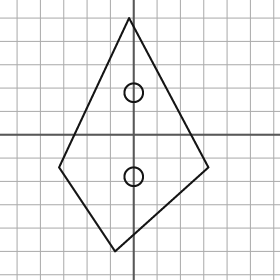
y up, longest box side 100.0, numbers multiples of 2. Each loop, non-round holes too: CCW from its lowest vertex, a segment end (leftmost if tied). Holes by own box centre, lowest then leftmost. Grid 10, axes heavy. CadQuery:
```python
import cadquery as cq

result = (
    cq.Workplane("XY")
    .moveTo(-8.0, -50.0)
    .lineTo(32.0, -14.0)
    .lineTo(-2.0, 50.0)
    .lineTo(-32.0, -14.0)
    .close()
    .moveTo(0.0, -18.0)
    .circle(4.0)
    .moveTo(0.0, 18.0)
    .circle(4.0)
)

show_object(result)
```